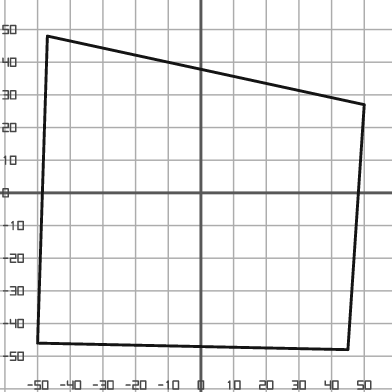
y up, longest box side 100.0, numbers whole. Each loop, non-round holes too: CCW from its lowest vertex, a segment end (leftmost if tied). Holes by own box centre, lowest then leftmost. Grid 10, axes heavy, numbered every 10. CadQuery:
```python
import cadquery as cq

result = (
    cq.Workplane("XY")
    .moveTo(45.0, -48.0)
    .lineTo(50.0, 27.0)
    .lineTo(-47.0, 48.0)
    .lineTo(-50.0, -46.0)
    .close()
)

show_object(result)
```